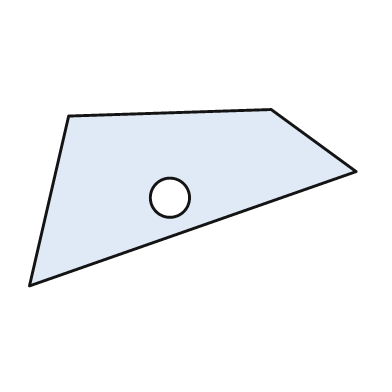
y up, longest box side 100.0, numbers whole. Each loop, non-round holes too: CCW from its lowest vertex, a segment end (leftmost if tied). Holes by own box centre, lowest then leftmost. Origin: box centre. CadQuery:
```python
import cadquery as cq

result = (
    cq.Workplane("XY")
    .moveTo(-50.0, -27.0)
    .lineTo(50.0, 8.0)
    .lineTo(24.0, 27.0)
    .lineTo(-38.0, 25.0)
    .close()
    .moveTo(-7.0, 0.0)
    .circle(6.0)
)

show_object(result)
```